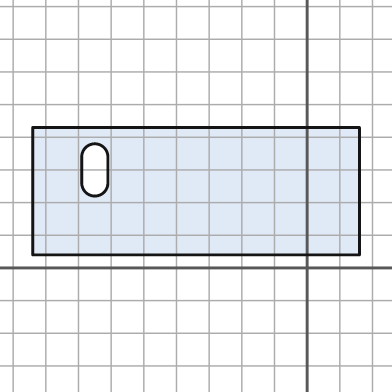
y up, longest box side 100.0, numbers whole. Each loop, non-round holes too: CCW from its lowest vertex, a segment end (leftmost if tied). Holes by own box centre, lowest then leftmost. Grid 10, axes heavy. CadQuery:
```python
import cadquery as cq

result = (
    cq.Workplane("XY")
    .moveTo(-84.0, 4.0)
    .lineTo(16.0, 4.0)
    .lineTo(16.0, 43.0)
    .lineTo(-84.0, 43.0)
    .close()
    .moveTo(-69.0, 26.0)
    .threePointArc((-65.0, 22.0), (-61.0, 26.0))
    .lineTo(-61.0, 34.0)
    .threePointArc((-65.0, 38.0), (-69.0, 34.0))
    .close()
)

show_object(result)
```